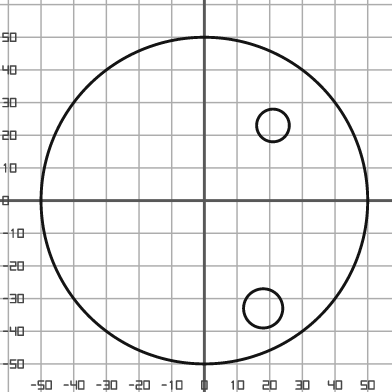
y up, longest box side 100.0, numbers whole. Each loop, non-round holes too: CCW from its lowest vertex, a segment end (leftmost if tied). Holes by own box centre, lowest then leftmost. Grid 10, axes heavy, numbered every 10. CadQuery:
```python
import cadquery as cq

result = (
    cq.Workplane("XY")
    .moveTo(0.0, 0.0)
    .circle(50.0)
    .moveTo(18.0, -33.0)
    .circle(6.0)
    .moveTo(21.0, 23.0)
    .circle(5.0)
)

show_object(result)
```